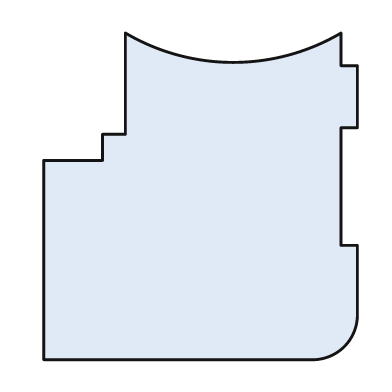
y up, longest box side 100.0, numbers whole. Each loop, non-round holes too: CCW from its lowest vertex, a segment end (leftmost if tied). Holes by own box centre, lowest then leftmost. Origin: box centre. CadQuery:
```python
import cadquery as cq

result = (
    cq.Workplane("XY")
    .moveTo(-48.0, -50.0)
    .lineTo(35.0, -50.0)
    .threePointArc((44.0, -46.0), (48.0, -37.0))
    .lineTo(48.0, -15.0)
    .lineTo(43.0, -15.0)
    .lineTo(43.0, 21.0)
    .lineTo(48.0, 21.0)
    .lineTo(48.0, 40.0)
    .lineTo(43.0, 40.0)
    .lineTo(43.0, 50.0)
    .threePointArc((10.0, 41.0), (-23.0, 50.0))
    .lineTo(-23.0, 19.0)
    .lineTo(-30.0, 19.0)
    .lineTo(-30.0, 11.0)
    .lineTo(-48.0, 11.0)
    .close()
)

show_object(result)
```